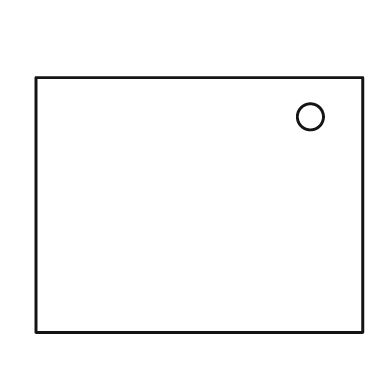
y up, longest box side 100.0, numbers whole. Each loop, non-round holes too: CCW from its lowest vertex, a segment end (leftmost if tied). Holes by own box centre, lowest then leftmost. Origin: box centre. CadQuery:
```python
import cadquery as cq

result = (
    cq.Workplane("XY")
    .moveTo(-50.0, -39.0)
    .lineTo(50.0, -39.0)
    .lineTo(50.0, 39.0)
    .lineTo(-50.0, 39.0)
    .close()
    .moveTo(34.0, 27.0)
    .circle(4.0)
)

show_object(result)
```